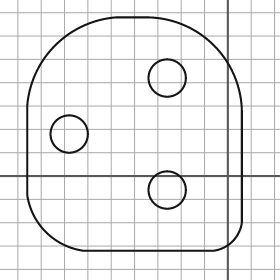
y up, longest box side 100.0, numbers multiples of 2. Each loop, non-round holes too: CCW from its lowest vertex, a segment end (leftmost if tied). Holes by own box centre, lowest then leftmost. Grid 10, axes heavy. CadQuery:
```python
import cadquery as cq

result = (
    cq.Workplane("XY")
    .moveTo(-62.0, -32.0)
    .lineTo(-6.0, -32.0)
    .threePointArc((2.0, -28.0), (6.0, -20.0))
    .lineTo(6.0, 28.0)
    .threePointArc((-6.0, 56.0), (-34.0, 68.0))
    .lineTo(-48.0, 68.0)
    .threePointArc((-74.0, 56.0), (-86.0, 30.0))
    .lineTo(-86.0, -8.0)
    .threePointArc((-78.0, -24.0), (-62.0, -32.0))
    .close()
    .moveTo(-26.0, -6.0)
    .circle(8.0)
    .moveTo(-68.0, 18.0)
    .circle(8.0)
    .moveTo(-26.0, 42.0)
    .circle(8.0)
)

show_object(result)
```